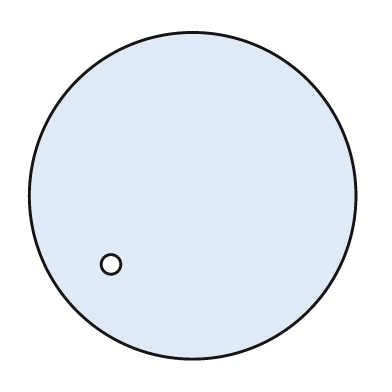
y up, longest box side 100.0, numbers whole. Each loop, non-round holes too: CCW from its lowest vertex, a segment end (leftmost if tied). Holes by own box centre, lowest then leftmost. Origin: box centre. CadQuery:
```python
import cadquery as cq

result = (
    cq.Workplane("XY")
    .moveTo(0.0, 0.0)
    .circle(50.0)
    .moveTo(-25.0, -21.0)
    .circle(3.0)
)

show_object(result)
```